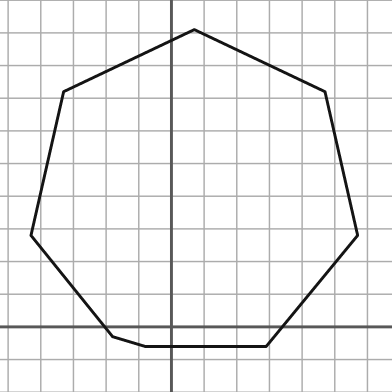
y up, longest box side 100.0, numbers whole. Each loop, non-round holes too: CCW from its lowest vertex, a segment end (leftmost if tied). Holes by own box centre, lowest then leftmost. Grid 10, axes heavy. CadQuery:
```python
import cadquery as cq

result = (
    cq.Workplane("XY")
    .moveTo(-8.0, -6.0)
    .lineTo(29.0, -6.0)
    .lineTo(57.0, 28.0)
    .lineTo(47.0, 72.0)
    .lineTo(7.0, 91.0)
    .lineTo(-33.0, 72.0)
    .lineTo(-43.0, 28.0)
    .lineTo(-18.0, -3.0)
    .close()
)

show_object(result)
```